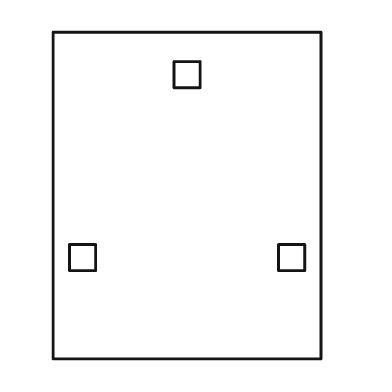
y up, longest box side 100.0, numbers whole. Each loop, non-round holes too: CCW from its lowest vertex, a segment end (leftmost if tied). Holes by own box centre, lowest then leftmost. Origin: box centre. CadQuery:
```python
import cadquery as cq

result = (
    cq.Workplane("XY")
    .moveTo(-41.0, -50.0)
    .lineTo(41.0, -50.0)
    .lineTo(41.0, 50.0)
    .lineTo(-41.0, 50.0)
    .close()
    .moveTo(-36.0, -23.0)
    .lineTo(-28.0, -23.0)
    .lineTo(-28.0, -15.0)
    .lineTo(-36.0, -15.0)
    .close()
    .moveTo(28.0, -23.0)
    .lineTo(36.0, -23.0)
    .lineTo(36.0, -15.0)
    .lineTo(28.0, -15.0)
    .close()
    .moveTo(-4.0, 33.0)
    .lineTo(4.0, 33.0)
    .lineTo(4.0, 41.0)
    .lineTo(-4.0, 41.0)
    .close()
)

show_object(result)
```